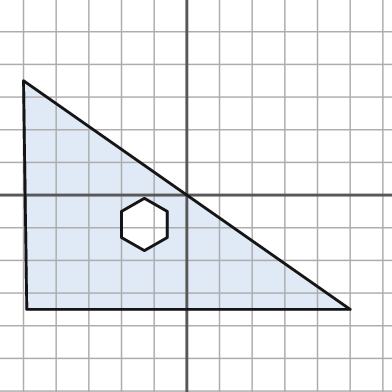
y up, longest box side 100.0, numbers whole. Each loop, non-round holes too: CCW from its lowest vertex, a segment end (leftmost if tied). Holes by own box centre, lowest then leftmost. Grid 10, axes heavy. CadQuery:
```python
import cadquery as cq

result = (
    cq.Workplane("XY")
    .moveTo(-49.0, -35.0)
    .lineTo(50.0, -35.0)
    .lineTo(-50.0, 35.0)
    .close()
    .moveTo(-13.0, -17.0)
    .lineTo(-6.0, -13.0)
    .lineTo(-6.0, -5.0)
    .lineTo(-13.0, -1.0)
    .lineTo(-20.0, -5.0)
    .lineTo(-20.0, -13.0)
    .close()
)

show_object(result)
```